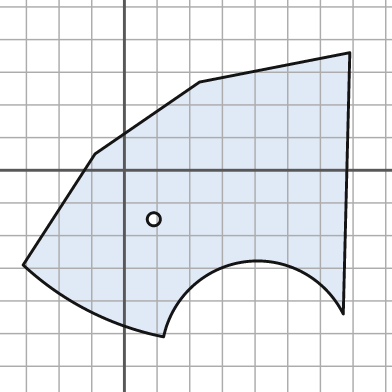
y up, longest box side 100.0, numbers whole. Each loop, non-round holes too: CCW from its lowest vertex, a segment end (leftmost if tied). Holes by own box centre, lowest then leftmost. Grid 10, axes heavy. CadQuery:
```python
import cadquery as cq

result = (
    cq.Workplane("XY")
    .moveTo(12.0, -51.0)
    .threePointArc((37.0, -28.0), (67.0, -44.0))
    .lineTo(69.0, 36.0)
    .lineTo(23.0, 27.0)
    .lineTo(-9.0, 5.0)
    .lineTo(-31.0, -29.0)
    .threePointArc((-11.0, -43.0), (12.0, -51.0))
    .close()
    .moveTo(9.0, -15.0)
    .circle(2.0)
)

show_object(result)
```